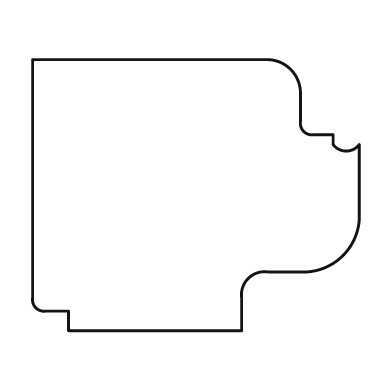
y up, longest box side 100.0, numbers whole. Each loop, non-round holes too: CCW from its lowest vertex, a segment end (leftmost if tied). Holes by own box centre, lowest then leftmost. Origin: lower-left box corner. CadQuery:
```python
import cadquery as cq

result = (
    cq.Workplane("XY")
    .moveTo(11.0, 0.0)
    .lineTo(64.0, 0.0)
    .lineTo(64.0, 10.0)
    .threePointArc((66.0, 16.0), (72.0, 18.0))
    .lineTo(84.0, 18.0)
    .threePointArc((95.0, 23.0), (100.0, 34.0))
    .lineTo(100.0, 57.0)
    .threePointArc((96.0, 55.0), (92.0, 57.0))
    .lineTo(92.0, 60.0)
    .lineTo(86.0, 60.0)
    .threePointArc((83.0, 61.0), (82.0, 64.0))
    .lineTo(82.0, 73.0)
    .threePointArc((79.0, 80.0), (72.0, 83.0))
    .lineTo(0.0, 83.0)
    .lineTo(0.0, 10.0)
    .threePointArc((1.0, 7.0), (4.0, 6.0))
    .lineTo(11.0, 6.0)
    .close()
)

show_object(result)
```